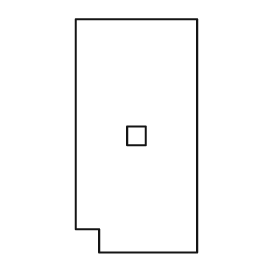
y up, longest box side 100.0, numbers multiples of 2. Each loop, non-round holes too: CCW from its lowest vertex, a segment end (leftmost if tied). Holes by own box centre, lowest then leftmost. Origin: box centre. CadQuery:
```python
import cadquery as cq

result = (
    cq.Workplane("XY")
    .moveTo(-16.0, -50.0)
    .lineTo(26.0, -50.0)
    .lineTo(26.0, 50.0)
    .lineTo(-26.0, 50.0)
    .lineTo(-26.0, -40.0)
    .lineTo(-16.0, -40.0)
    .close()
    .moveTo(-4.0, -4.0)
    .lineTo(4.0, -4.0)
    .lineTo(4.0, 4.0)
    .lineTo(-4.0, 4.0)
    .close()
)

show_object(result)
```